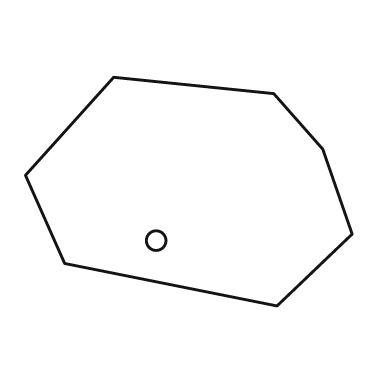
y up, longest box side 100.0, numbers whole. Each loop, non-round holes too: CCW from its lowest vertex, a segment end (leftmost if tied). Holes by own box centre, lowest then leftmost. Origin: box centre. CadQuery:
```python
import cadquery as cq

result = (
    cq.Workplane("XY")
    .moveTo(27.0, -35.0)
    .lineTo(50.0, -13.0)
    .lineTo(41.0, 13.0)
    .lineTo(26.0, 30.0)
    .lineTo(-23.0, 35.0)
    .lineTo(-50.0, 5.0)
    .lineTo(-38.0, -22.0)
    .close()
    .moveTo(-10.0, -15.0)
    .circle(3.0)
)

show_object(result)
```